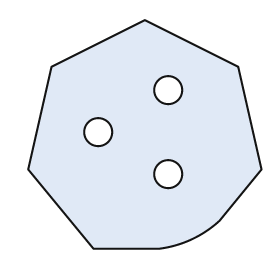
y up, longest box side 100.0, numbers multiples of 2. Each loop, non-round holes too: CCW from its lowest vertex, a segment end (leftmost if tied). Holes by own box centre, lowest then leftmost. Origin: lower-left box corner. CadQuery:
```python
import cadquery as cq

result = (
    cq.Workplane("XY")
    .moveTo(28.0, 0.0)
    .lineTo(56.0, 0.0)
    .threePointArc((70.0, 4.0), (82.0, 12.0))
    .lineTo(100.0, 34.0)
    .lineTo(90.0, 78.0)
    .lineTo(50.0, 98.0)
    .lineTo(10.0, 78.0)
    .lineTo(0.0, 34.0)
    .close()
    .moveTo(60.0, 32.0)
    .circle(6.0)
    .moveTo(30.0, 50.0)
    .circle(6.0)
    .moveTo(60.0, 68.0)
    .circle(6.0)
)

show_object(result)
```